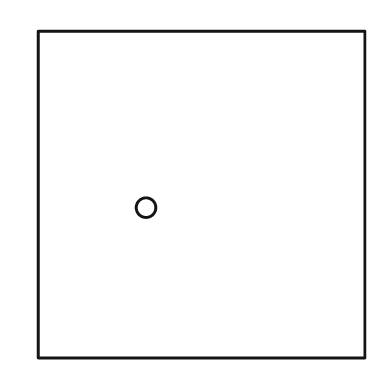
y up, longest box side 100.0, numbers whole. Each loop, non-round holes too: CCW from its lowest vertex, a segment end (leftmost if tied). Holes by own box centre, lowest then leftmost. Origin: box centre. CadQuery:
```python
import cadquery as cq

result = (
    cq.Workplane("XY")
    .moveTo(-50.0, -50.0)
    .lineTo(50.0, -50.0)
    .lineTo(50.0, 50.0)
    .lineTo(-50.0, 50.0)
    .close()
    .moveTo(-17.0, -4.0)
    .circle(3.0)
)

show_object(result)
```